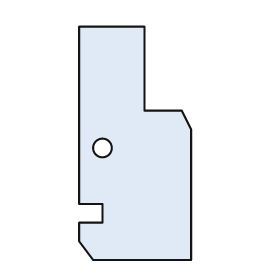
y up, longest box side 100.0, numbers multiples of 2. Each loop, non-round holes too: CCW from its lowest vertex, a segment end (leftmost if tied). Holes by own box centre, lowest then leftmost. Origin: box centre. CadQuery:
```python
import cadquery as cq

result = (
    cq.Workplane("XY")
    .moveTo(-18.0, -50.0)
    .lineTo(24.0, -50.0)
    .lineTo(24.0, 6.0)
    .lineTo(20.0, 14.0)
    .lineTo(4.0, 14.0)
    .lineTo(4.0, 50.0)
    .lineTo(-24.0, 50.0)
    .lineTo(-24.0, -26.0)
    .lineTo(-14.0, -26.0)
    .lineTo(-14.0, -34.0)
    .lineTo(-24.0, -34.0)
    .lineTo(-24.0, -42.0)
    .close()
    .moveTo(-14.0, -2.0)
    .circle(4.0)
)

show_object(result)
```